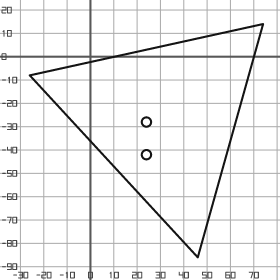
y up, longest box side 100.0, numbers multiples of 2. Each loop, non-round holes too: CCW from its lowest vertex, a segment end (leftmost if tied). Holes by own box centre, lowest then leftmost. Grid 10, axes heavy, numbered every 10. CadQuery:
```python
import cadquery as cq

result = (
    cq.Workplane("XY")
    .moveTo(46.0, -86.0)
    .lineTo(74.0, 14.0)
    .lineTo(-26.0, -8.0)
    .close()
    .moveTo(24.0, -42.0)
    .circle(2.0)
    .moveTo(24.0, -28.0)
    .circle(2.0)
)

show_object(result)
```